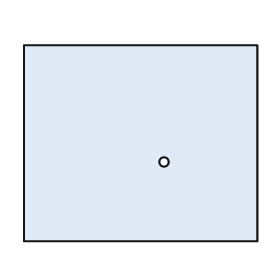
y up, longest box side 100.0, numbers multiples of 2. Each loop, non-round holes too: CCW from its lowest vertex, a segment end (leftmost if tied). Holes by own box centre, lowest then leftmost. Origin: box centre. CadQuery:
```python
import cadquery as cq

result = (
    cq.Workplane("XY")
    .moveTo(-50.0, -42.0)
    .lineTo(50.0, -42.0)
    .lineTo(50.0, 42.0)
    .lineTo(-50.0, 42.0)
    .close()
    .moveTo(10.0, -8.0)
    .circle(2.0)
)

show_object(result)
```